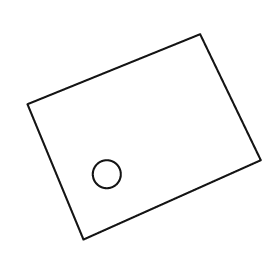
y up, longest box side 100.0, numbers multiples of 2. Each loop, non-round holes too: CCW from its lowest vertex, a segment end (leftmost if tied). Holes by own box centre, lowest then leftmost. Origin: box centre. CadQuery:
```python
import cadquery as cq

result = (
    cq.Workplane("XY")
    .moveTo(-26.0, -44.0)
    .lineTo(50.0, -10.0)
    .lineTo(24.0, 44.0)
    .lineTo(-50.0, 14.0)
    .close()
    .moveTo(-16.0, -16.0)
    .circle(6.0)
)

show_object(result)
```